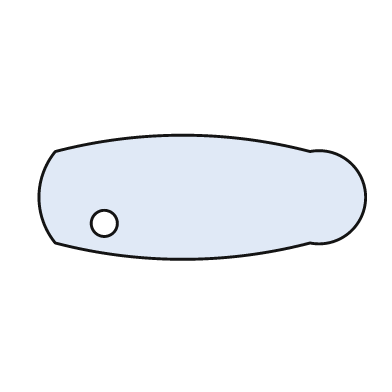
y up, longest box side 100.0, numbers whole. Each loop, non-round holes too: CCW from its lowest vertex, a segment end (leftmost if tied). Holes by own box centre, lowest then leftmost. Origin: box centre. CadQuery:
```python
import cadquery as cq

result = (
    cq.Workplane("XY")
    .moveTo(-45.0, -14.0)
    .threePointArc((-6.0, -19.0), (33.0, -14.0))
    .threePointArc((50.0, 0.0), (33.0, 14.0))
    .threePointArc((-6.0, 19.0), (-45.0, 14.0))
    .threePointArc((-50.0, 0.0), (-45.0, -14.0))
    .close()
    .moveTo(-30.0, -8.0)
    .circle(4.0)
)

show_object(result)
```